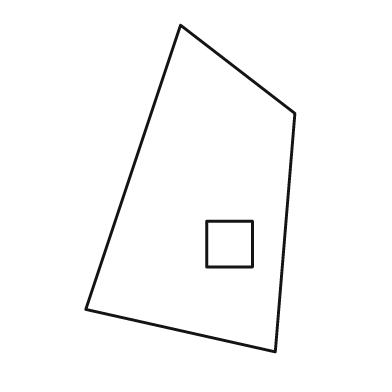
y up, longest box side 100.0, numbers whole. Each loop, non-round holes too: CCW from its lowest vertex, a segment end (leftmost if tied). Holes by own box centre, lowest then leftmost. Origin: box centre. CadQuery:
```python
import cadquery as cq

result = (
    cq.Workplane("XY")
    .moveTo(26.0, -50.0)
    .lineTo(32.0, 23.0)
    .lineTo(-3.0, 50.0)
    .lineTo(-32.0, -37.0)
    .close()
    .moveTo(5.0, -24.0)
    .lineTo(19.0, -24.0)
    .lineTo(19.0, -10.0)
    .lineTo(5.0, -10.0)
    .close()
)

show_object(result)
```